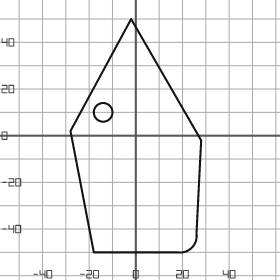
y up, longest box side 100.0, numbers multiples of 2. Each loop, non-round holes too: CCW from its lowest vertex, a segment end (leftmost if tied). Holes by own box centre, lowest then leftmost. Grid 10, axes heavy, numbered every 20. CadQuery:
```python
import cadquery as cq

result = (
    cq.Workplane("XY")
    .moveTo(-18.0, -50.0)
    .lineTo(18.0, -50.0)
    .threePointArc((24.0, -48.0), (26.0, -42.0))
    .lineTo(28.0, -2.0)
    .lineTo(-2.0, 50.0)
    .lineTo(-28.0, 2.0)
    .close()
    .moveTo(-14.0, 10.0)
    .circle(4.0)
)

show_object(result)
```